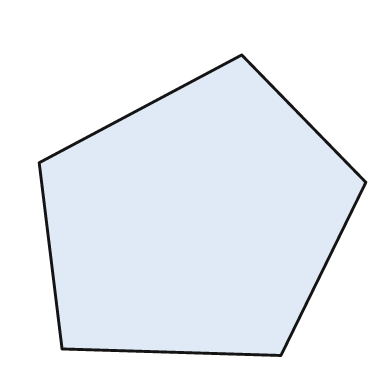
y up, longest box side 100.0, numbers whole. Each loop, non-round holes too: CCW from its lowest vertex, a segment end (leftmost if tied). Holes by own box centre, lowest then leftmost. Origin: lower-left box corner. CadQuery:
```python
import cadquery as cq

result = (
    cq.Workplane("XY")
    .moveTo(74.0, 0.0)
    .lineTo(100.0, 53.0)
    .lineTo(62.0, 92.0)
    .lineTo(0.0, 59.0)
    .lineTo(7.0, 2.0)
    .close()
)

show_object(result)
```